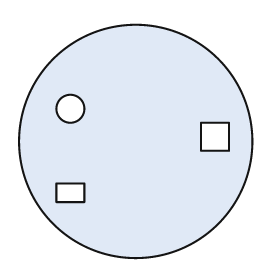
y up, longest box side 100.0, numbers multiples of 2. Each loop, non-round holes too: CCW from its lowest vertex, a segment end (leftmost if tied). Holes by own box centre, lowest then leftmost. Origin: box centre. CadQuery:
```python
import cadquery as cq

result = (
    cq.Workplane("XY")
    .moveTo(0.0, 0.0)
    .circle(50.0)
    .moveTo(-34.0, -26.0)
    .lineTo(-22.0, -26.0)
    .lineTo(-22.0, -18.0)
    .lineTo(-34.0, -18.0)
    .close()
    .moveTo(28.0, -4.0)
    .lineTo(40.0, -4.0)
    .lineTo(40.0, 8.0)
    .lineTo(28.0, 8.0)
    .close()
    .moveTo(-28.0, 14.0)
    .circle(6.0)
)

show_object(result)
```